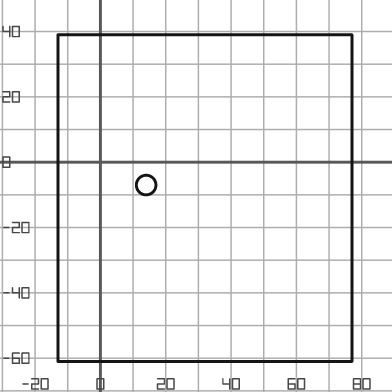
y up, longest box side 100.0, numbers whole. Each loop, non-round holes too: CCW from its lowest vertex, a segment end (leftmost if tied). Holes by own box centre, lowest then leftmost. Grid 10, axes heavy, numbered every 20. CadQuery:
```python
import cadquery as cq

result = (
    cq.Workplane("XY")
    .moveTo(-13.0, -61.0)
    .lineTo(77.0, -61.0)
    .lineTo(77.0, 39.0)
    .lineTo(-13.0, 39.0)
    .close()
    .moveTo(14.0, -7.0)
    .circle(3.0)
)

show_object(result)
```